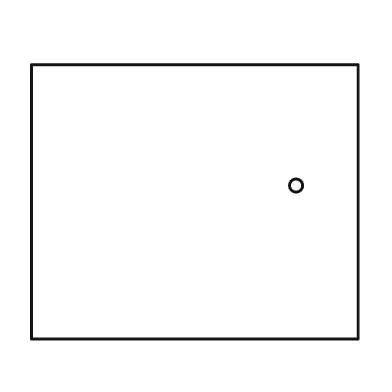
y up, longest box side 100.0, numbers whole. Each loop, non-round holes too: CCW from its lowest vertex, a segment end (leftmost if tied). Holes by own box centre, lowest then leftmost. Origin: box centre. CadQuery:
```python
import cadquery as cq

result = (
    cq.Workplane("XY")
    .moveTo(-50.0, -42.0)
    .lineTo(50.0, -42.0)
    .lineTo(50.0, 42.0)
    .lineTo(-50.0, 42.0)
    .close()
    .moveTo(31.0, 5.0)
    .circle(2.0)
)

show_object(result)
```